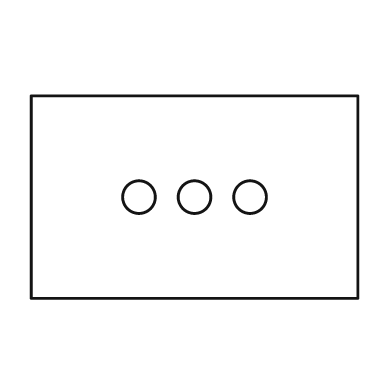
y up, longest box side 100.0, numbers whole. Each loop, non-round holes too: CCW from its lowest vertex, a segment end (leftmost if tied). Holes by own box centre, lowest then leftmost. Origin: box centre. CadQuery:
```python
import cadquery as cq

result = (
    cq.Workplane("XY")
    .moveTo(-50.0, -31.0)
    .lineTo(50.0, -31.0)
    .lineTo(50.0, 31.0)
    .lineTo(-50.0, 31.0)
    .close()
    .moveTo(-17.0, 0.0)
    .circle(5.0)
    .moveTo(0.0, 0.0)
    .circle(5.0)
    .moveTo(17.0, 0.0)
    .circle(5.0)
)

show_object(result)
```